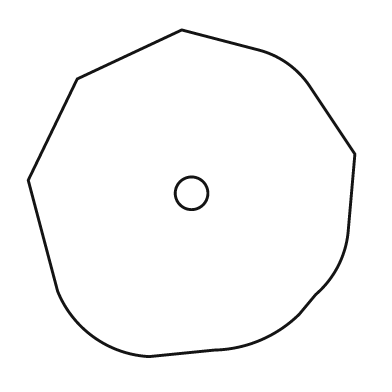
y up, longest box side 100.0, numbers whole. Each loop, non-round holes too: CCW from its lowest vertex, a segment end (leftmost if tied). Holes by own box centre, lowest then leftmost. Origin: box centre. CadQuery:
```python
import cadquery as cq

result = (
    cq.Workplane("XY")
    .moveTo(-13.0, -50.0)
    .lineTo(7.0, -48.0)
    .threePointArc((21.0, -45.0), (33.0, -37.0))
    .lineTo(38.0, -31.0)
    .threePointArc((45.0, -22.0), (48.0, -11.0))
    .lineTo(50.0, 12.0)
    .lineTo(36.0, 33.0)
    .threePointArc((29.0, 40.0), (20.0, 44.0))
    .lineTo(-3.0, 50.0)
    .lineTo(-35.0, 35.0)
    .lineTo(-50.0, 4.0)
    .lineTo(-41.0, -30.0)
    .threePointArc((-30.0, -44.0), (-13.0, -50.0))
    .close()
    .moveTo(0.0, 0.0)
    .circle(5.0)
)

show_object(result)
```